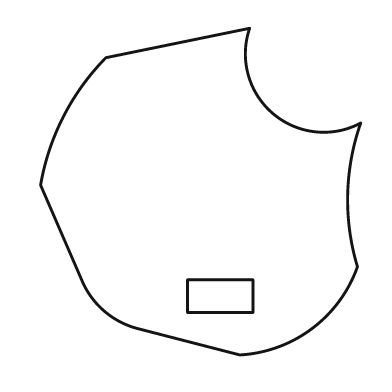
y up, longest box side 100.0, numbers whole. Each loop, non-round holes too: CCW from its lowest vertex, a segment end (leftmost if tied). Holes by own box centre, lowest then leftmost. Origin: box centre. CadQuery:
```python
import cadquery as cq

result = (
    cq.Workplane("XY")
    .moveTo(12.0, -50.0)
    .threePointArc((34.0, -42.0), (48.0, -23.0))
    .threePointArc((45.0, -1.0), (49.0, 21.0))
    .threePointArc((22.0, 24.0), (15.0, 50.0))
    .lineTo(-29.0, 41.0)
    .threePointArc((-42.0, 23.0), (-49.0, 2.0))
    .lineTo(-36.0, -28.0)
    .threePointArc((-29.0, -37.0), (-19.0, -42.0))
    .close()
    .moveTo(-4.0, -37.0)
    .lineTo(16.0, -37.0)
    .lineTo(16.0, -27.0)
    .lineTo(-4.0, -27.0)
    .close()
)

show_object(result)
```